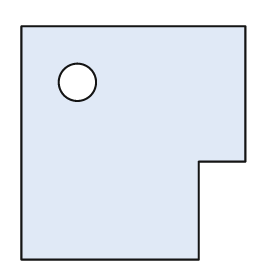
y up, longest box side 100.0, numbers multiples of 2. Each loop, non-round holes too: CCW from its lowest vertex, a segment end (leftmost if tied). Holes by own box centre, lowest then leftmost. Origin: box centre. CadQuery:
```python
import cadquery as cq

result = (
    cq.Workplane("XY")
    .moveTo(-48.0, -50.0)
    .lineTo(28.0, -50.0)
    .lineTo(28.0, -8.0)
    .lineTo(48.0, -8.0)
    .lineTo(48.0, 50.0)
    .lineTo(-48.0, 50.0)
    .close()
    .moveTo(-24.0, 26.0)
    .circle(8.0)
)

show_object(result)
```